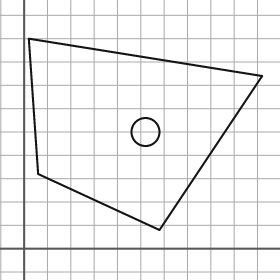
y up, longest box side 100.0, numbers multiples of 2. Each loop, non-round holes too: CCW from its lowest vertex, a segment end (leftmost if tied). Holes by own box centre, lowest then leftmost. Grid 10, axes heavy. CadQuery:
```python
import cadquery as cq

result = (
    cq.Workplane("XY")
    .moveTo(58.0, 8.0)
    .lineTo(102.0, 74.0)
    .lineTo(2.0, 90.0)
    .lineTo(6.0, 32.0)
    .close()
    .moveTo(52.0, 50.0)
    .circle(6.0)
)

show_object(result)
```